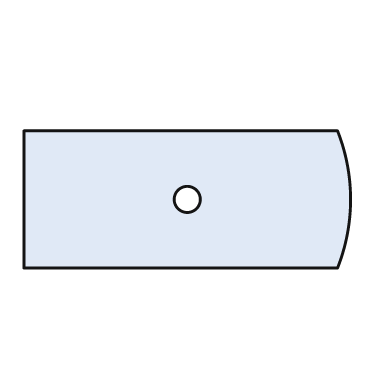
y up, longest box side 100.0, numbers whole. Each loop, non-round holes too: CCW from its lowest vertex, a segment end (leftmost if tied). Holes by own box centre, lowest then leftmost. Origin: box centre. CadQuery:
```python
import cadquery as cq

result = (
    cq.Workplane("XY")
    .moveTo(-50.0, -21.0)
    .lineTo(46.0, -21.0)
    .threePointArc((50.0, 0.0), (46.0, 21.0))
    .lineTo(-50.0, 21.0)
    .close()
    .moveTo(0.0, 0.0)
    .circle(4.0)
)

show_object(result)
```